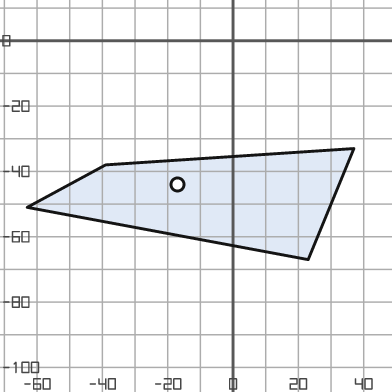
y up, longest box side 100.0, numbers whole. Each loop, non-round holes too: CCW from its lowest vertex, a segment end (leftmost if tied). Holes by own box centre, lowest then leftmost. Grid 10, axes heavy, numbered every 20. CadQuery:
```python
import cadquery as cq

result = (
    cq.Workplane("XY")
    .moveTo(23.0, -67.0)
    .lineTo(37.0, -33.0)
    .lineTo(-39.0, -38.0)
    .lineTo(-63.0, -51.0)
    .close()
    .moveTo(-17.0, -44.0)
    .circle(2.0)
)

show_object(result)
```